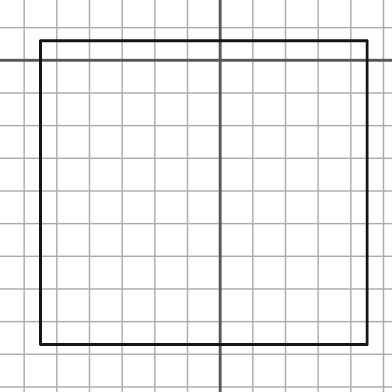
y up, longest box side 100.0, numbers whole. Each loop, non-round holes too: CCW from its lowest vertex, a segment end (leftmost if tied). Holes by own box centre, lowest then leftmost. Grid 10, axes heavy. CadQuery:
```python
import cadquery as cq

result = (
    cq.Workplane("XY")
    .moveTo(-55.0, -87.0)
    .lineTo(45.0, -87.0)
    .lineTo(45.0, 6.0)
    .lineTo(-55.0, 6.0)
    .close()
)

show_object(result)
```